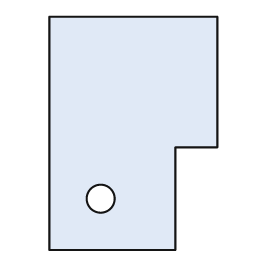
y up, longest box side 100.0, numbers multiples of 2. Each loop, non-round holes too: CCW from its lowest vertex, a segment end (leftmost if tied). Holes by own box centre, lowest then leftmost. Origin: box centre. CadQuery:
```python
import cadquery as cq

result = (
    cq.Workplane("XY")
    .moveTo(-36.0, -50.0)
    .lineTo(18.0, -50.0)
    .lineTo(18.0, -6.0)
    .lineTo(36.0, -6.0)
    .lineTo(36.0, 50.0)
    .lineTo(-36.0, 50.0)
    .close()
    .moveTo(-14.0, -28.0)
    .circle(6.0)
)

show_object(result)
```